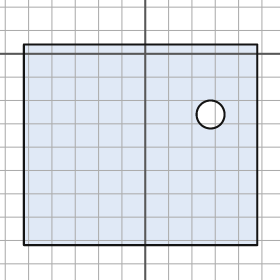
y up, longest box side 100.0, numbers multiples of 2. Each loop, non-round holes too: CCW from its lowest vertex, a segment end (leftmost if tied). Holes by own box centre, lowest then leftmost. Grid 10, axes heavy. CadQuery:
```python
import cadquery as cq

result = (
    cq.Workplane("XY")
    .moveTo(-52.0, -82.0)
    .lineTo(48.0, -82.0)
    .lineTo(48.0, 4.0)
    .lineTo(-52.0, 4.0)
    .close()
    .moveTo(28.0, -26.0)
    .circle(6.0)
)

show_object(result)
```